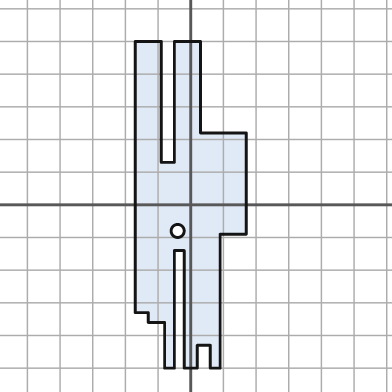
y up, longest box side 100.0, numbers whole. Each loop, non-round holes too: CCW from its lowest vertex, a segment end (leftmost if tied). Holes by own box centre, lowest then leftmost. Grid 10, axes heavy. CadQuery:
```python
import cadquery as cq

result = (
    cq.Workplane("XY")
    .moveTo(-8.0, -50.0)
    .lineTo(-5.0, -50.0)
    .lineTo(-5.0, -14.0)
    .lineTo(-2.0, -14.0)
    .lineTo(-2.0, -50.0)
    .lineTo(2.0, -50.0)
    .lineTo(2.0, -43.0)
    .lineTo(6.0, -43.0)
    .lineTo(6.0, -50.0)
    .lineTo(9.0, -50.0)
    .lineTo(9.0, -9.0)
    .lineTo(17.0, -9.0)
    .lineTo(17.0, 22.0)
    .lineTo(3.0, 22.0)
    .lineTo(3.0, 50.0)
    .lineTo(-5.0, 50.0)
    .lineTo(-5.0, 13.0)
    .lineTo(-9.0, 13.0)
    .lineTo(-9.0, 50.0)
    .lineTo(-17.0, 50.0)
    .lineTo(-17.0, -33.0)
    .lineTo(-13.0, -33.0)
    .lineTo(-13.0, -36.0)
    .lineTo(-8.0, -36.0)
    .close()
    .moveTo(-4.0, -8.0)
    .circle(2.0)
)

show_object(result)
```